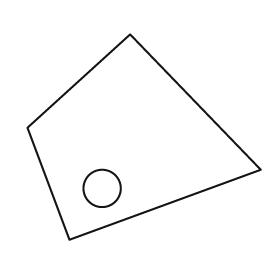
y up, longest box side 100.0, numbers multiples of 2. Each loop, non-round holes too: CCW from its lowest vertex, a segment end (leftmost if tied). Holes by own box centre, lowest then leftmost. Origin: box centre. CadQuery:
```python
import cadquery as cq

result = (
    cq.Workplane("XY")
    .moveTo(-32.0, -44.0)
    .lineTo(50.0, -14.0)
    .lineTo(-6.0, 44.0)
    .lineTo(-50.0, 4.0)
    .close()
    .moveTo(-18.0, -22.0)
    .circle(8.0)
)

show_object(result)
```